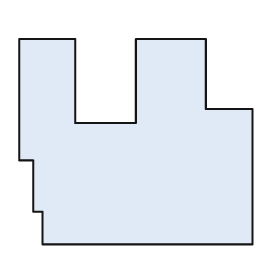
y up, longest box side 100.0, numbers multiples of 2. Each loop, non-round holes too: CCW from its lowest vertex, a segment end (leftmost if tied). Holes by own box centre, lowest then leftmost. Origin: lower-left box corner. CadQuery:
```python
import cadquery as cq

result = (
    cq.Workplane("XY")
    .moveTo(10.0, 0.0)
    .lineTo(100.0, 0.0)
    .lineTo(100.0, 58.0)
    .lineTo(80.0, 58.0)
    .lineTo(80.0, 88.0)
    .lineTo(50.0, 88.0)
    .lineTo(50.0, 52.0)
    .lineTo(24.0, 52.0)
    .lineTo(24.0, 88.0)
    .lineTo(0.0, 88.0)
    .lineTo(0.0, 36.0)
    .lineTo(6.0, 36.0)
    .lineTo(6.0, 14.0)
    .lineTo(10.0, 14.0)
    .close()
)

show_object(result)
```